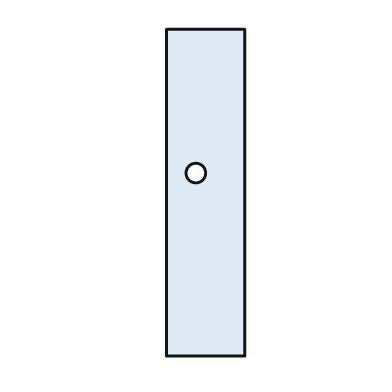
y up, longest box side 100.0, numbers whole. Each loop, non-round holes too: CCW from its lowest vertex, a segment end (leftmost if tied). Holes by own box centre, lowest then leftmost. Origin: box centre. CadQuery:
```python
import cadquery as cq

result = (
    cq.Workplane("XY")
    .moveTo(-12.0, -50.0)
    .lineTo(12.0, -50.0)
    .lineTo(12.0, 50.0)
    .lineTo(-12.0, 50.0)
    .close()
    .moveTo(-3.0, 6.0)
    .circle(3.0)
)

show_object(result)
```